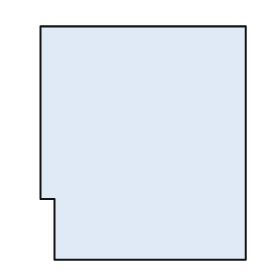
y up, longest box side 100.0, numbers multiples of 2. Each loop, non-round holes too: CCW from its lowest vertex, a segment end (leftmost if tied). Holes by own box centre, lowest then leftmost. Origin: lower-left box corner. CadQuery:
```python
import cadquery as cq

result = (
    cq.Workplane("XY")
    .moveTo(6.0, 0.0)
    .lineTo(88.0, 0.0)
    .lineTo(88.0, 100.0)
    .lineTo(0.0, 100.0)
    .lineTo(0.0, 26.0)
    .lineTo(6.0, 26.0)
    .close()
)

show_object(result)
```